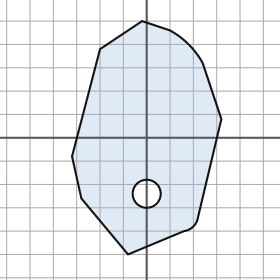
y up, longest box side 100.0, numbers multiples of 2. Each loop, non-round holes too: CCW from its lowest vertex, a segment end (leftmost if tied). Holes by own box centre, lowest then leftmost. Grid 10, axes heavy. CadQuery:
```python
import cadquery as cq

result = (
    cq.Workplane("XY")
    .moveTo(-8.0, -50.0)
    .lineTo(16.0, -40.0)
    .threePointArc((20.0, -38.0), (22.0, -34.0))
    .lineTo(32.0, 8.0)
    .lineTo(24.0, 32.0)
    .threePointArc((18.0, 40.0), (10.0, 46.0))
    .lineTo(-2.0, 50.0)
    .lineTo(-20.0, 38.0)
    .lineTo(-32.0, -8.0)
    .lineTo(-28.0, -26.0)
    .close()
    .moveTo(0.0, -24.0)
    .circle(6.0)
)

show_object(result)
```